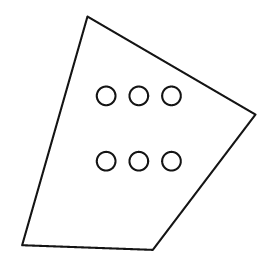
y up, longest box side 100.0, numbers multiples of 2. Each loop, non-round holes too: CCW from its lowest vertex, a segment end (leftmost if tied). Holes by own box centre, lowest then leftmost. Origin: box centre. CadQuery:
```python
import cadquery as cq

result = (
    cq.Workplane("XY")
    .moveTo(6.0, -50.0)
    .lineTo(50.0, 8.0)
    .lineTo(-22.0, 50.0)
    .lineTo(-50.0, -48.0)
    .close()
    .moveTo(-14.0, -12.0)
    .circle(4.0)
    .moveTo(0.0, -12.0)
    .circle(4.0)
    .moveTo(14.0, -12.0)
    .circle(4.0)
    .moveTo(-14.0, 16.0)
    .circle(4.0)
    .moveTo(0.0, 16.0)
    .circle(4.0)
    .moveTo(14.0, 16.0)
    .circle(4.0)
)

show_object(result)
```